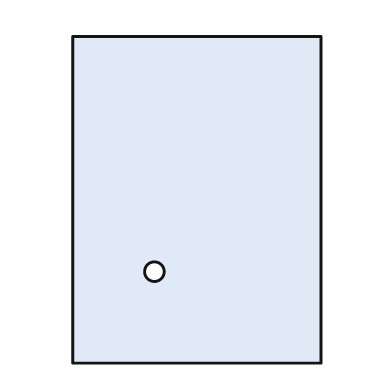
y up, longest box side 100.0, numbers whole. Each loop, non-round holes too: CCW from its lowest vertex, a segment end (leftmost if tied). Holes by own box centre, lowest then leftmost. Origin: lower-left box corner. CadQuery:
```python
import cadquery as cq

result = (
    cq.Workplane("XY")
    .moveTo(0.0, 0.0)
    .lineTo(76.0, 0.0)
    .lineTo(76.0, 100.0)
    .lineTo(0.0, 100.0)
    .close()
    .moveTo(25.0, 28.0)
    .circle(3.0)
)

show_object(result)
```